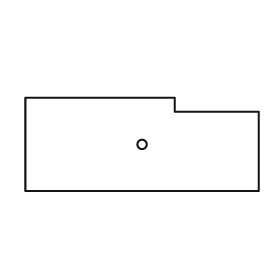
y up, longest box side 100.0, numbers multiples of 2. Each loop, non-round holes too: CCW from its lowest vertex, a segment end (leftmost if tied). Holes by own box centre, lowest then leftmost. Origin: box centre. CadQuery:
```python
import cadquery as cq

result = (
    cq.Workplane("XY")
    .moveTo(-50.0, -20.0)
    .lineTo(50.0, -20.0)
    .lineTo(50.0, 14.0)
    .lineTo(14.0, 14.0)
    .lineTo(14.0, 20.0)
    .lineTo(-50.0, 20.0)
    .close()
    .moveTo(0.0, 0.0)
    .circle(2.0)
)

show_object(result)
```